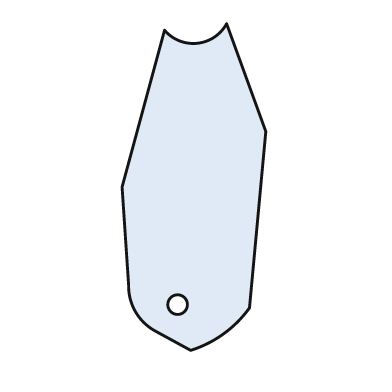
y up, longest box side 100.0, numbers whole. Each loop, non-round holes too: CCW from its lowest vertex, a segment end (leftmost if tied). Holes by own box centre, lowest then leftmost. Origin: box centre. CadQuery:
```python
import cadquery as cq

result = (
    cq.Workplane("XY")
    .moveTo(-1.0, -50.0)
    .threePointArc((9.0, -45.0), (17.0, -37.0))
    .lineTo(22.0, 17.0)
    .lineTo(10.0, 50.0)
    .threePointArc((1.0, 44.0), (-9.0, 48.0))
    .lineTo(-22.0, 0.0)
    .lineTo(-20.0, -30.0)
    .threePointArc((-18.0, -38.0), (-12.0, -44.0))
    .close()
    .moveTo(-5.0, -36.0)
    .circle(3.0)
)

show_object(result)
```